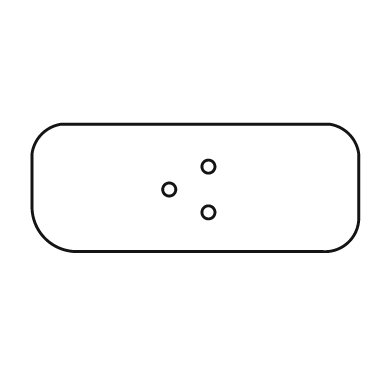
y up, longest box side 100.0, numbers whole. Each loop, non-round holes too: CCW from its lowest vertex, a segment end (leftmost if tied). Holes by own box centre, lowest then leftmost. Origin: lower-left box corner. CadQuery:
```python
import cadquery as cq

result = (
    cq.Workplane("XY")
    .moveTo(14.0, 0.0)
    .lineTo(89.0, 0.0)
    .threePointArc((97.0, 3.0), (100.0, 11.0))
    .lineTo(100.0, 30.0)
    .threePointArc((97.0, 36.0), (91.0, 39.0))
    .lineTo(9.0, 39.0)
    .threePointArc((3.0, 36.0), (0.0, 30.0))
    .lineTo(0.0, 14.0)
    .threePointArc((4.0, 4.0), (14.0, 0.0))
    .close()
    .moveTo(54.0, 12.0)
    .circle(2.0)
    .moveTo(42.0, 19.0)
    .circle(2.0)
    .moveTo(54.0, 26.0)
    .circle(2.0)
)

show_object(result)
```